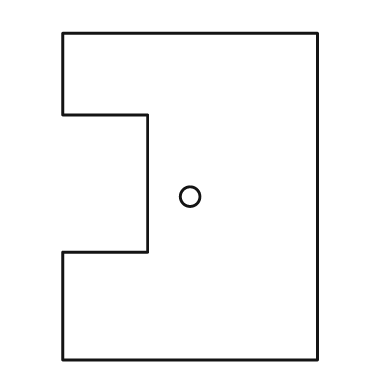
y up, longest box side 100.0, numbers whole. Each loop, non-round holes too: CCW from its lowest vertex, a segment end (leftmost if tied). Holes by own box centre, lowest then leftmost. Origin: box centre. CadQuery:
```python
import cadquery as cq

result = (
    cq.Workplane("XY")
    .moveTo(-39.0, -50.0)
    .lineTo(39.0, -50.0)
    .lineTo(39.0, 50.0)
    .lineTo(-39.0, 50.0)
    .lineTo(-39.0, 25.0)
    .lineTo(-13.0, 25.0)
    .lineTo(-13.0, -17.0)
    .lineTo(-39.0, -17.0)
    .close()
    .moveTo(0.0, 0.0)
    .circle(3.0)
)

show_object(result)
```